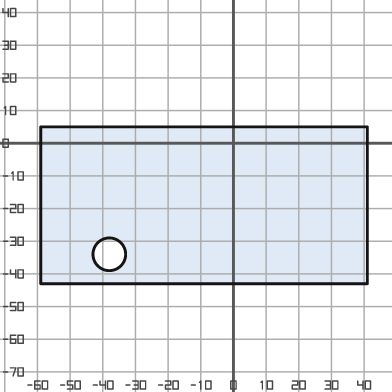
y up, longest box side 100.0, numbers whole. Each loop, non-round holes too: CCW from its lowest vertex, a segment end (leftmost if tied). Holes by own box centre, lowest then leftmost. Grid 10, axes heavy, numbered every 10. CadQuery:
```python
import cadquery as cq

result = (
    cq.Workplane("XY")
    .moveTo(-59.0, -43.0)
    .lineTo(41.0, -43.0)
    .lineTo(41.0, 5.0)
    .lineTo(-59.0, 5.0)
    .close()
    .moveTo(-38.0, -34.0)
    .circle(5.0)
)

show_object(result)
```